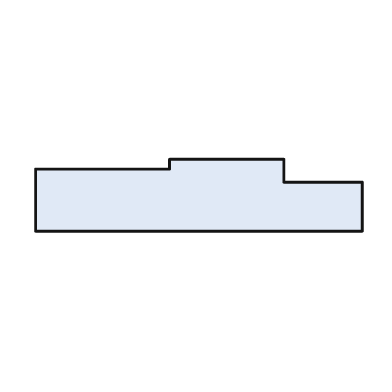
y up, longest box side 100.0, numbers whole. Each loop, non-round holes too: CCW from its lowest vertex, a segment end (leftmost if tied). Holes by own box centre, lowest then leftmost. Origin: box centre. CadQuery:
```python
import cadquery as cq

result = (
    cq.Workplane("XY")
    .moveTo(-50.0, -11.0)
    .lineTo(50.0, -11.0)
    .lineTo(50.0, 4.0)
    .lineTo(26.0, 4.0)
    .lineTo(26.0, 11.0)
    .lineTo(-9.0, 11.0)
    .lineTo(-9.0, 8.0)
    .lineTo(-50.0, 8.0)
    .close()
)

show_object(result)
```